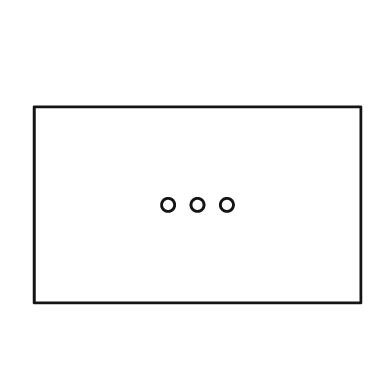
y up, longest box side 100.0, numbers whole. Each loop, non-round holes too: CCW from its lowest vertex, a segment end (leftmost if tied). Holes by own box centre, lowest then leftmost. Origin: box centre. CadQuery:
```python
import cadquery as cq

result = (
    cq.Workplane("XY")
    .moveTo(-50.0, -30.0)
    .lineTo(50.0, -30.0)
    .lineTo(50.0, 30.0)
    .lineTo(-50.0, 30.0)
    .close()
    .moveTo(-9.0, 0.0)
    .circle(2.0)
    .moveTo(0.0, 0.0)
    .circle(2.0)
    .moveTo(9.0, 0.0)
    .circle(2.0)
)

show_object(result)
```